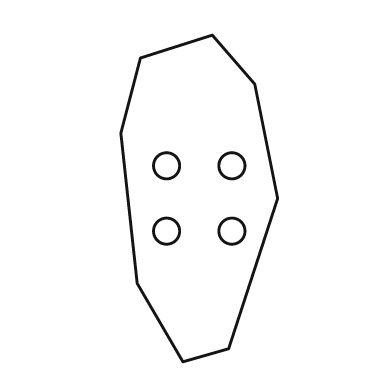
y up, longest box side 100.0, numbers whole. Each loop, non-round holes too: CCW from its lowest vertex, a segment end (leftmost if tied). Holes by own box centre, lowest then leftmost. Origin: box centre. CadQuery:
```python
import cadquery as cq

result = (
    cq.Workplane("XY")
    .moveTo(-5.0, -50.0)
    .lineTo(9.0, -46.0)
    .lineTo(24.0, 0.0)
    .lineTo(17.0, 35.0)
    .lineTo(4.0, 50.0)
    .lineTo(-18.0, 43.0)
    .lineTo(-24.0, 20.0)
    .lineTo(-19.0, -26.0)
    .close()
    .moveTo(-10.0, -10.0)
    .circle(4.0)
    .moveTo(10.0, -10.0)
    .circle(4.0)
    .moveTo(-10.0, 10.0)
    .circle(4.0)
    .moveTo(10.0, 10.0)
    .circle(4.0)
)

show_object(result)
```